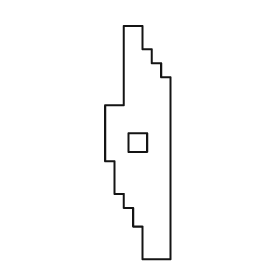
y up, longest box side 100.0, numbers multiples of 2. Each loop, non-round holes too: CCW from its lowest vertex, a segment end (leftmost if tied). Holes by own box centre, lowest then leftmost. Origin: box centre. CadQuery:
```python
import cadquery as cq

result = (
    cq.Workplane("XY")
    .moveTo(2.0, -50.0)
    .lineTo(14.0, -50.0)
    .lineTo(14.0, 28.0)
    .lineTo(10.0, 28.0)
    .lineTo(10.0, 34.0)
    .lineTo(6.0, 34.0)
    .lineTo(6.0, 40.0)
    .lineTo(2.0, 40.0)
    .lineTo(2.0, 50.0)
    .lineTo(-6.0, 50.0)
    .lineTo(-6.0, 16.0)
    .lineTo(-14.0, 16.0)
    .lineTo(-14.0, -8.0)
    .lineTo(-10.0, -8.0)
    .lineTo(-10.0, -22.0)
    .lineTo(-6.0, -22.0)
    .lineTo(-6.0, -28.0)
    .lineTo(-2.0, -28.0)
    .lineTo(-2.0, -36.0)
    .lineTo(2.0, -36.0)
    .close()
    .moveTo(-4.0, -4.0)
    .lineTo(4.0, -4.0)
    .lineTo(4.0, 4.0)
    .lineTo(-4.0, 4.0)
    .close()
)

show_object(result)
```